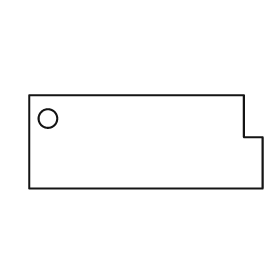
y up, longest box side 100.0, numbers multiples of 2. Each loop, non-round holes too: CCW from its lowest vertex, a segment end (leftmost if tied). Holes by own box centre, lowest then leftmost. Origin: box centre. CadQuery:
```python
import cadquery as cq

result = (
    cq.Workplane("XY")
    .moveTo(-50.0, -20.0)
    .lineTo(50.0, -20.0)
    .lineTo(50.0, 2.0)
    .lineTo(42.0, 2.0)
    .lineTo(42.0, 20.0)
    .lineTo(-50.0, 20.0)
    .close()
    .moveTo(-42.0, 10.0)
    .circle(4.0)
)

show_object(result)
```